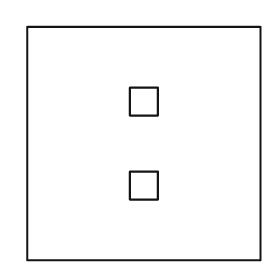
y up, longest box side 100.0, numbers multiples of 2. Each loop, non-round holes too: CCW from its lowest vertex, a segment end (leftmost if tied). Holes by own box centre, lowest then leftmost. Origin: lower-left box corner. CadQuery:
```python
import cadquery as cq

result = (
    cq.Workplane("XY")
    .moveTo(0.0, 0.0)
    .lineTo(100.0, 0.0)
    .lineTo(100.0, 100.0)
    .lineTo(0.0, 100.0)
    .close()
    .moveTo(44.0, 26.0)
    .lineTo(56.0, 26.0)
    .lineTo(56.0, 38.0)
    .lineTo(44.0, 38.0)
    .close()
    .moveTo(44.0, 62.0)
    .lineTo(56.0, 62.0)
    .lineTo(56.0, 74.0)
    .lineTo(44.0, 74.0)
    .close()
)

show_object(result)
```